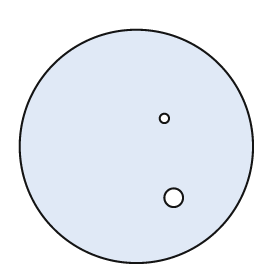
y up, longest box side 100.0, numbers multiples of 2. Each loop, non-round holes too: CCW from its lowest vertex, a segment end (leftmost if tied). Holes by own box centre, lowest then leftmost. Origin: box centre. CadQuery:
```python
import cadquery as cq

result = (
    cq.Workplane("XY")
    .moveTo(0.0, 0.0)
    .circle(50.0)
    .moveTo(16.0, -22.0)
    .circle(4.0)
    .moveTo(12.0, 12.0)
    .circle(2.0)
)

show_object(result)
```